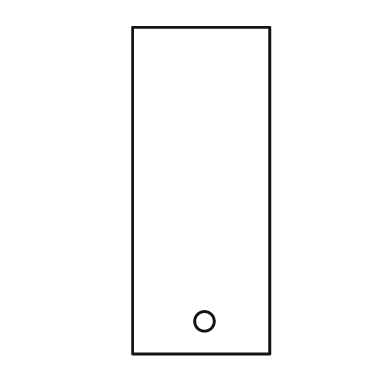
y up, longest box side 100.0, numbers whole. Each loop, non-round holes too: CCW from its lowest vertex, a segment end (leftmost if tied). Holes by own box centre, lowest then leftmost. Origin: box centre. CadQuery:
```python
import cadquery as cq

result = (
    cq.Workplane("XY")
    .moveTo(-21.0, -50.0)
    .lineTo(21.0, -50.0)
    .lineTo(21.0, 50.0)
    .lineTo(-21.0, 50.0)
    .close()
    .moveTo(1.0, -40.0)
    .circle(3.0)
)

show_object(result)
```